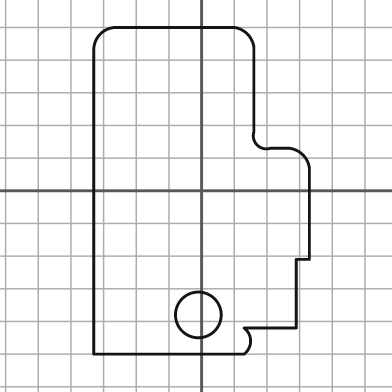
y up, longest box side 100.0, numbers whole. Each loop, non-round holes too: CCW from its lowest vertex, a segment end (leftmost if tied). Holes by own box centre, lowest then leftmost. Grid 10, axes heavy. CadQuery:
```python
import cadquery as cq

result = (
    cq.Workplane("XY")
    .moveTo(-33.0, -50.0)
    .lineTo(13.0, -50.0)
    .threePointArc((15.0, -46.0), (13.0, -42.0))
    .lineTo(29.0, -42.0)
    .lineTo(29.0, -21.0)
    .lineTo(33.0, -21.0)
    .lineTo(33.0, 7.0)
    .threePointArc((31.0, 11.0), (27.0, 13.0))
    .lineTo(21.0, 13.0)
    .threePointArc((17.0, 14.0), (16.0, 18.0))
    .lineTo(16.0, 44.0)
    .threePointArc((14.0, 48.0), (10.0, 50.0))
    .lineTo(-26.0, 50.0)
    .threePointArc((-31.0, 48.0), (-33.0, 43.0))
    .close()
    .moveTo(-1.0, -38.0)
    .circle(7.0)
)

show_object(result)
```